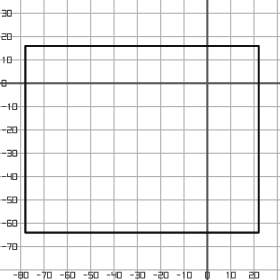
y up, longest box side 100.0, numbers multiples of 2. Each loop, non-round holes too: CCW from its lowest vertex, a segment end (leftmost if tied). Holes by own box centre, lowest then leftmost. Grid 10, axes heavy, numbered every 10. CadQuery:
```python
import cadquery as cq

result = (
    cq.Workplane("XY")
    .moveTo(-78.0, -64.0)
    .lineTo(22.0, -64.0)
    .lineTo(22.0, 16.0)
    .lineTo(-78.0, 16.0)
    .close()
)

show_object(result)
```